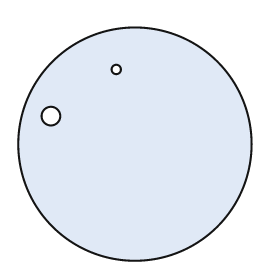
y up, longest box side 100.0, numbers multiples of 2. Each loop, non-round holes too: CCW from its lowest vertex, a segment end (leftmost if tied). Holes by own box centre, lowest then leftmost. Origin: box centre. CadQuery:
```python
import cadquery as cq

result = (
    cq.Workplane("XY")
    .moveTo(0.0, 0.0)
    .circle(50.0)
    .moveTo(-36.0, 12.0)
    .circle(4.0)
    .moveTo(-8.0, 32.0)
    .circle(2.0)
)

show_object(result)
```